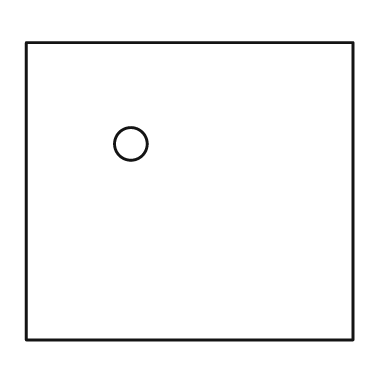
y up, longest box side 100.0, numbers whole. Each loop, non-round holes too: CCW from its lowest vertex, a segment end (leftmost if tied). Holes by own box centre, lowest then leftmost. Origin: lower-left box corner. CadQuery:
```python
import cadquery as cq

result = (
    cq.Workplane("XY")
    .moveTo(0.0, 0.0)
    .lineTo(100.0, 0.0)
    .lineTo(100.0, 91.0)
    .lineTo(0.0, 91.0)
    .close()
    .moveTo(32.0, 60.0)
    .circle(5.0)
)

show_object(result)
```